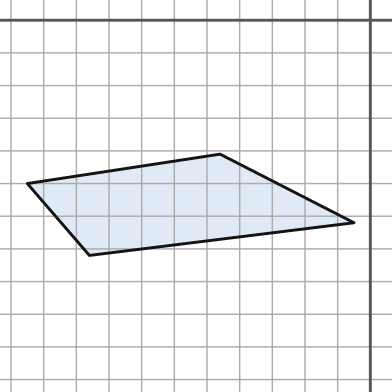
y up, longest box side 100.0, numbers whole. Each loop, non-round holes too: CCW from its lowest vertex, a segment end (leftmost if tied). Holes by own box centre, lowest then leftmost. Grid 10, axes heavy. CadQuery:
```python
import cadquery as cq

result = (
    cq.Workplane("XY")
    .moveTo(-86.0, -72.0)
    .lineTo(-5.0, -62.0)
    .lineTo(-46.0, -41.0)
    .lineTo(-105.0, -50.0)
    .close()
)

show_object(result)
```